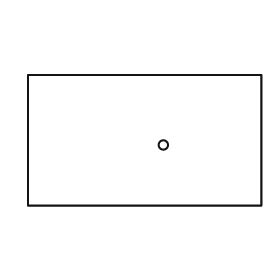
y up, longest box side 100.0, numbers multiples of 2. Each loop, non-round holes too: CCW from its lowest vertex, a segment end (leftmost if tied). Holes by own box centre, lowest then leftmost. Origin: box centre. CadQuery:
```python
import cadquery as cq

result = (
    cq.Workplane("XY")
    .moveTo(-50.0, -28.0)
    .lineTo(50.0, -28.0)
    .lineTo(50.0, 28.0)
    .lineTo(-50.0, 28.0)
    .close()
    .moveTo(8.0, -2.0)
    .circle(2.0)
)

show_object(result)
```